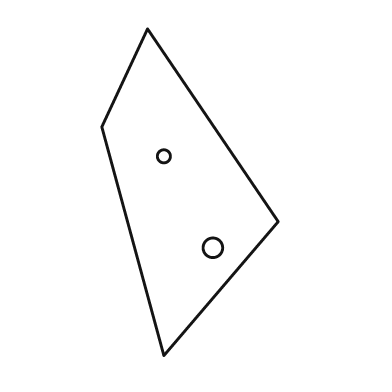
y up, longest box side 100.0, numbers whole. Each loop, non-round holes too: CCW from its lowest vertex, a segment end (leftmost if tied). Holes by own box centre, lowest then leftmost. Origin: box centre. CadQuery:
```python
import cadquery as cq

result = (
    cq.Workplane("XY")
    .moveTo(-8.0, -50.0)
    .lineTo(27.0, -9.0)
    .lineTo(-13.0, 50.0)
    .lineTo(-27.0, 20.0)
    .close()
    .moveTo(7.0, -17.0)
    .circle(3.0)
    .moveTo(-8.0, 11.0)
    .circle(2.0)
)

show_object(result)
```